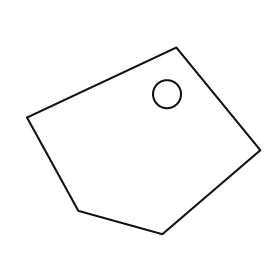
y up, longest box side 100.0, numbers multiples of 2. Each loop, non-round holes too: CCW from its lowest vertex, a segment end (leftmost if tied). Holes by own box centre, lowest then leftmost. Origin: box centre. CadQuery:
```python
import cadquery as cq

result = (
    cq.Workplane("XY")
    .moveTo(8.0, -40.0)
    .lineTo(50.0, -4.0)
    .lineTo(14.0, 40.0)
    .lineTo(-50.0, 10.0)
    .lineTo(-28.0, -30.0)
    .close()
    .moveTo(10.0, 20.0)
    .circle(6.0)
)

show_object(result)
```